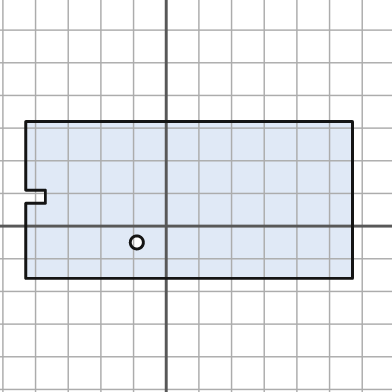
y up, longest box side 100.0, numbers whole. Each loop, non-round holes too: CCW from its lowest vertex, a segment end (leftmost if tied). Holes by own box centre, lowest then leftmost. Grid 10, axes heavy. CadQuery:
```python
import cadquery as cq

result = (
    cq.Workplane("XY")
    .moveTo(-43.0, -16.0)
    .lineTo(57.0, -16.0)
    .lineTo(57.0, 32.0)
    .lineTo(-43.0, 32.0)
    .lineTo(-43.0, 11.0)
    .lineTo(-37.0, 11.0)
    .lineTo(-37.0, 7.0)
    .lineTo(-43.0, 7.0)
    .close()
    .moveTo(-9.0, -5.0)
    .circle(2.0)
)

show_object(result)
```